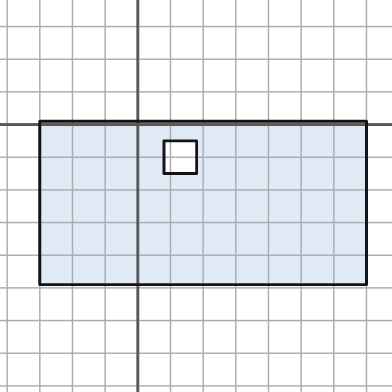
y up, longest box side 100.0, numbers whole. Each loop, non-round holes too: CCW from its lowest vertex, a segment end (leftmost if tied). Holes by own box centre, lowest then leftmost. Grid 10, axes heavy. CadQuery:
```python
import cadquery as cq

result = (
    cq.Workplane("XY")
    .moveTo(-30.0, -49.0)
    .lineTo(70.0, -49.0)
    .lineTo(70.0, 1.0)
    .lineTo(-30.0, 1.0)
    .close()
    .moveTo(8.0, -15.0)
    .lineTo(18.0, -15.0)
    .lineTo(18.0, -5.0)
    .lineTo(8.0, -5.0)
    .close()
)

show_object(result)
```